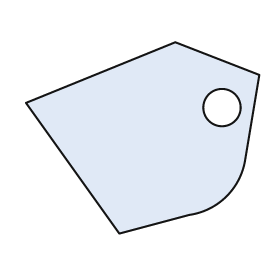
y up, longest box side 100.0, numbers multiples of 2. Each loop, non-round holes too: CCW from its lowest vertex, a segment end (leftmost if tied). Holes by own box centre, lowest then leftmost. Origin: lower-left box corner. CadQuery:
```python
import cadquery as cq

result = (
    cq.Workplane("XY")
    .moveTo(40.0, 0.0)
    .lineTo(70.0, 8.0)
    .threePointArc((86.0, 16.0), (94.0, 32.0))
    .lineTo(100.0, 68.0)
    .lineTo(64.0, 82.0)
    .lineTo(0.0, 56.0)
    .close()
    .moveTo(84.0, 54.0)
    .circle(8.0)
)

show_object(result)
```